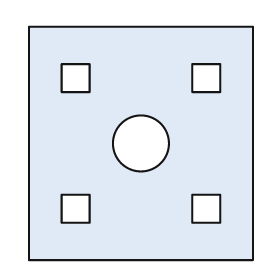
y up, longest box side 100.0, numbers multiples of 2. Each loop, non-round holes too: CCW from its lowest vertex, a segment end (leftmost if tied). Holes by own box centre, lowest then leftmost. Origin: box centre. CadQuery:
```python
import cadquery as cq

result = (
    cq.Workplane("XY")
    .moveTo(-48.0, -50.0)
    .lineTo(48.0, -50.0)
    .lineTo(48.0, 50.0)
    .lineTo(-48.0, 50.0)
    .close()
    .moveTo(-34.0, -34.0)
    .lineTo(-22.0, -34.0)
    .lineTo(-22.0, -22.0)
    .lineTo(-34.0, -22.0)
    .close()
    .moveTo(22.0, -34.0)
    .lineTo(34.0, -34.0)
    .lineTo(34.0, -22.0)
    .lineTo(22.0, -22.0)
    .close()
    .moveTo(0.0, 0.0)
    .circle(12.0)
    .moveTo(-34.0, 22.0)
    .lineTo(-22.0, 22.0)
    .lineTo(-22.0, 34.0)
    .lineTo(-34.0, 34.0)
    .close()
    .moveTo(22.0, 22.0)
    .lineTo(34.0, 22.0)
    .lineTo(34.0, 34.0)
    .lineTo(22.0, 34.0)
    .close()
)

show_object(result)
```